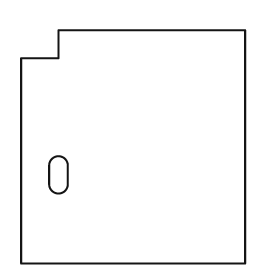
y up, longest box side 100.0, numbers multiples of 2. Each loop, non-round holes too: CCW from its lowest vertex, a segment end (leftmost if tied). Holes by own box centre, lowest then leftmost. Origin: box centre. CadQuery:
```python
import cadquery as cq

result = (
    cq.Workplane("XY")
    .moveTo(-48.0, -50.0)
    .lineTo(48.0, -50.0)
    .lineTo(48.0, 50.0)
    .lineTo(-32.0, 50.0)
    .lineTo(-32.0, 38.0)
    .lineTo(-48.0, 38.0)
    .close()
    .moveTo(-36.0, -16.0)
    .threePointArc((-32.0, -20.0), (-28.0, -16.0))
    .lineTo(-28.0, -8.0)
    .threePointArc((-32.0, -4.0), (-36.0, -8.0))
    .close()
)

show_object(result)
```